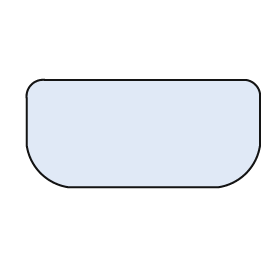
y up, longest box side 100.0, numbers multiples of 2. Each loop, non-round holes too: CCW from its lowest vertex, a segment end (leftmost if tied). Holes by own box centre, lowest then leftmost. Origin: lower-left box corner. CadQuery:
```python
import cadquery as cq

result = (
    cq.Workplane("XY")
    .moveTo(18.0, 0.0)
    .lineTo(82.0, 0.0)
    .threePointArc((94.0, 6.0), (100.0, 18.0))
    .lineTo(100.0, 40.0)
    .threePointArc((98.0, 44.0), (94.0, 46.0))
    .lineTo(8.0, 46.0)
    .threePointArc((2.0, 44.0), (0.0, 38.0))
    .lineTo(0.0, 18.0)
    .threePointArc((6.0, 6.0), (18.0, 0.0))
    .close()
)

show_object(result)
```